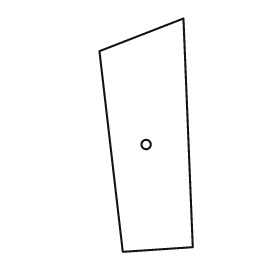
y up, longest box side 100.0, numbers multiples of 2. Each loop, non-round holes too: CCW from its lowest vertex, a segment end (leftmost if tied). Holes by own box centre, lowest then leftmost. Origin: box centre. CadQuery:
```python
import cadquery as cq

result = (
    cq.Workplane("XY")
    .moveTo(-10.0, -50.0)
    .lineTo(20.0, -48.0)
    .lineTo(16.0, 50.0)
    .lineTo(-20.0, 36.0)
    .close()
    .moveTo(0.0, -4.0)
    .circle(2.0)
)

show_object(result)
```